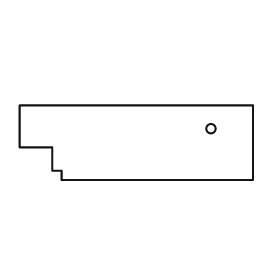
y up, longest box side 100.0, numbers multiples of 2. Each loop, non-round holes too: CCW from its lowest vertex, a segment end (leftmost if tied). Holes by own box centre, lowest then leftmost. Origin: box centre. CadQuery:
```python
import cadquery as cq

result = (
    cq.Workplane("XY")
    .moveTo(-32.0, -16.0)
    .lineTo(50.0, -16.0)
    .lineTo(50.0, 16.0)
    .lineTo(-50.0, 16.0)
    .lineTo(-50.0, -2.0)
    .lineTo(-36.0, -2.0)
    .lineTo(-36.0, -12.0)
    .lineTo(-32.0, -12.0)
    .close()
    .moveTo(32.0, 6.0)
    .circle(2.0)
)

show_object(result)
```